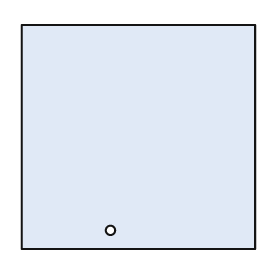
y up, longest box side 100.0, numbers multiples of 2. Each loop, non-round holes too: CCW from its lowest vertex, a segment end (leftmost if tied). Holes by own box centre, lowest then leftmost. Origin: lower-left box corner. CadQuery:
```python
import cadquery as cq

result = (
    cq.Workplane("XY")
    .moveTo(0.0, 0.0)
    .lineTo(100.0, 0.0)
    .lineTo(100.0, 96.0)
    .lineTo(0.0, 96.0)
    .close()
    .moveTo(38.0, 8.0)
    .circle(2.0)
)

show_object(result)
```